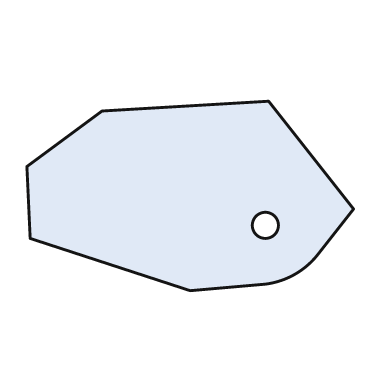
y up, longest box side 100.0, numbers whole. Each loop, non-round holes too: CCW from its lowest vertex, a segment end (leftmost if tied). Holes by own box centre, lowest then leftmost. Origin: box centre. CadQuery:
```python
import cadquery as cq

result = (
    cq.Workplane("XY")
    .moveTo(0.0, -29.0)
    .lineTo(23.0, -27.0)
    .threePointArc((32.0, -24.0), (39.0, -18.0))
    .lineTo(50.0, -4.0)
    .lineTo(24.0, 29.0)
    .lineTo(-27.0, 26.0)
    .lineTo(-50.0, 9.0)
    .lineTo(-49.0, -13.0)
    .close()
    .moveTo(23.0, -9.0)
    .circle(4.0)
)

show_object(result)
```